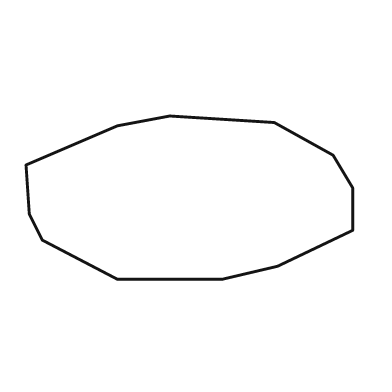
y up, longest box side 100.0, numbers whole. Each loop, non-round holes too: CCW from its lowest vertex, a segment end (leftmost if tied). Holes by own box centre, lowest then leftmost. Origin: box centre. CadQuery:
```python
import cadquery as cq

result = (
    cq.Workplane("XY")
    .moveTo(-22.0, -25.0)
    .lineTo(10.0, -25.0)
    .lineTo(27.0, -21.0)
    .lineTo(50.0, -10.0)
    .lineTo(50.0, 3.0)
    .lineTo(44.0, 13.0)
    .lineTo(26.0, 23.0)
    .lineTo(-6.0, 25.0)
    .lineTo(-22.0, 22.0)
    .lineTo(-50.0, 10.0)
    .lineTo(-49.0, -5.0)
    .lineTo(-45.0, -13.0)
    .close()
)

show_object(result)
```